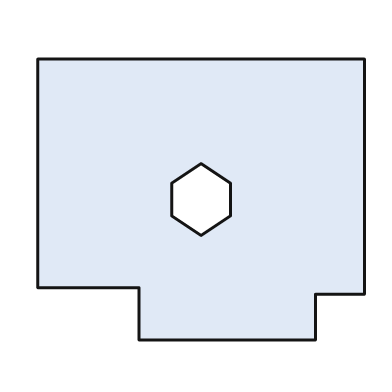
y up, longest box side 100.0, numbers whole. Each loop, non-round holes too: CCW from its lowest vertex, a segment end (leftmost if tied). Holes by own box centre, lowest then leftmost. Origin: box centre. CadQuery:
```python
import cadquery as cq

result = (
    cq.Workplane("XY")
    .moveTo(-19.0, -43.0)
    .lineTo(35.0, -43.0)
    .lineTo(35.0, -29.0)
    .lineTo(50.0, -29.0)
    .lineTo(50.0, 43.0)
    .lineTo(-50.0, 43.0)
    .lineTo(-50.0, -27.0)
    .lineTo(-19.0, -27.0)
    .close()
    .moveTo(0.0, -11.0)
    .lineTo(9.0, -5.0)
    .lineTo(9.0, 5.0)
    .lineTo(0.0, 11.0)
    .lineTo(-9.0, 5.0)
    .lineTo(-9.0, -5.0)
    .close()
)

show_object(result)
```